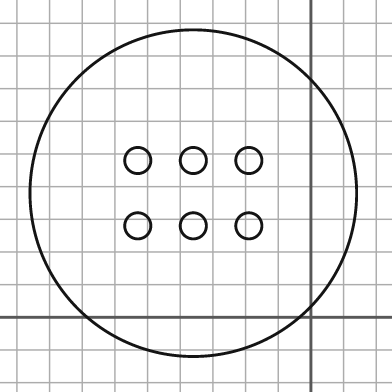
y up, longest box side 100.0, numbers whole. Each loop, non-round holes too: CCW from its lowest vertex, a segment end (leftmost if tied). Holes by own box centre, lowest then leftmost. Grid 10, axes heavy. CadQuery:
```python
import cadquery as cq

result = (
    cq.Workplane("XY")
    .moveTo(-36.0, 38.0)
    .circle(50.0)
    .moveTo(-53.0, 28.0)
    .circle(4.0)
    .moveTo(-36.0, 28.0)
    .circle(4.0)
    .moveTo(-19.0, 28.0)
    .circle(4.0)
    .moveTo(-53.0, 48.0)
    .circle(4.0)
    .moveTo(-36.0, 48.0)
    .circle(4.0)
    .moveTo(-19.0, 48.0)
    .circle(4.0)
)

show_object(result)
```